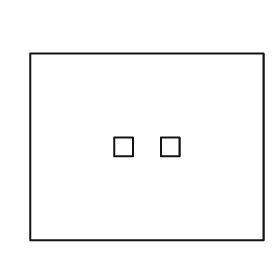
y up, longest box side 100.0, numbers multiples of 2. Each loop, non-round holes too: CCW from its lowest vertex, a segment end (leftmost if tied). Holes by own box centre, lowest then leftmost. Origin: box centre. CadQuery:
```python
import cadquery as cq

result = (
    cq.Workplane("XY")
    .moveTo(-50.0, -40.0)
    .lineTo(50.0, -40.0)
    .lineTo(50.0, 40.0)
    .lineTo(-50.0, 40.0)
    .close()
    .moveTo(-14.0, -4.0)
    .lineTo(-6.0, -4.0)
    .lineTo(-6.0, 4.0)
    .lineTo(-14.0, 4.0)
    .close()
    .moveTo(6.0, -4.0)
    .lineTo(14.0, -4.0)
    .lineTo(14.0, 4.0)
    .lineTo(6.0, 4.0)
    .close()
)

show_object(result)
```